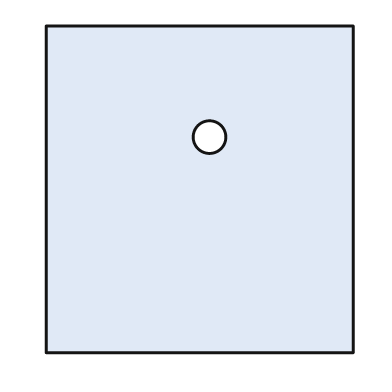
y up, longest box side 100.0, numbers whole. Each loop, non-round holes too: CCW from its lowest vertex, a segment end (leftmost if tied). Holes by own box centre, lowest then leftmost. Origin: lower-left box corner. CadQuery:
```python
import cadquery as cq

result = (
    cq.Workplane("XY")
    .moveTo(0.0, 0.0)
    .lineTo(94.0, 0.0)
    .lineTo(94.0, 100.0)
    .lineTo(0.0, 100.0)
    .close()
    .moveTo(50.0, 66.0)
    .circle(5.0)
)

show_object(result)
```